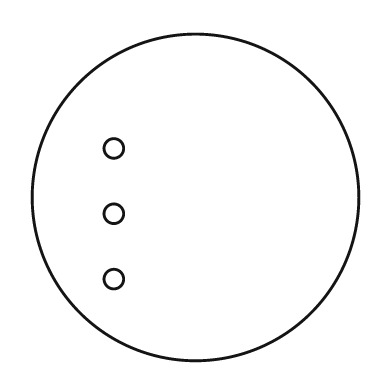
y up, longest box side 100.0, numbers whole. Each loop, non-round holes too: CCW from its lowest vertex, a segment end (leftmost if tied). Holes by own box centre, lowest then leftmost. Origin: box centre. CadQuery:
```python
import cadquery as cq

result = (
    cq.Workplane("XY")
    .moveTo(0.0, 0.0)
    .circle(50.0)
    .moveTo(-25.0, -25.0)
    .circle(3.0)
    .moveTo(-25.0, -5.0)
    .circle(3.0)
    .moveTo(-25.0, 15.0)
    .circle(3.0)
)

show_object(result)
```